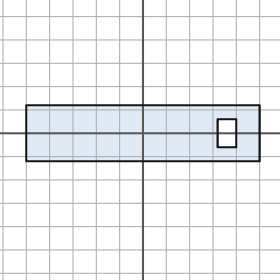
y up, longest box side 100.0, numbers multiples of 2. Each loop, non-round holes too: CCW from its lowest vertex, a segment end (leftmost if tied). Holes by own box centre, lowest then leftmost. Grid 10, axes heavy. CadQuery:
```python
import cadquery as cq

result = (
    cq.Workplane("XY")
    .moveTo(-50.0, -12.0)
    .lineTo(50.0, -12.0)
    .lineTo(50.0, 12.0)
    .lineTo(-50.0, 12.0)
    .close()
    .moveTo(32.0, -6.0)
    .lineTo(40.0, -6.0)
    .lineTo(40.0, 6.0)
    .lineTo(32.0, 6.0)
    .close()
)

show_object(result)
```